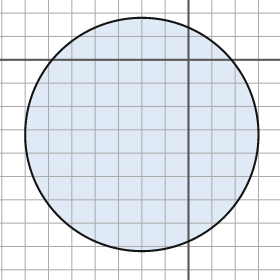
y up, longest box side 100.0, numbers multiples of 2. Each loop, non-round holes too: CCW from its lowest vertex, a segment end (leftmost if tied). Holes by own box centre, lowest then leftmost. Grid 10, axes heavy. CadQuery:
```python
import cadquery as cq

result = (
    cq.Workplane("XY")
    .moveTo(-20.0, -32.0)
    .circle(50.0)
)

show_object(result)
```